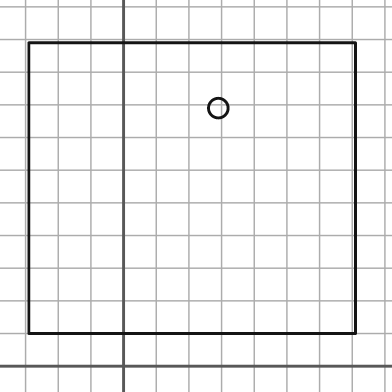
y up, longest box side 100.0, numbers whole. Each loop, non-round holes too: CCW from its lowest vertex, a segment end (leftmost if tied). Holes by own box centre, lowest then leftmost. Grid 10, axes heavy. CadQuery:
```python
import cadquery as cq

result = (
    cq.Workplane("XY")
    .moveTo(-29.0, 10.0)
    .lineTo(71.0, 10.0)
    .lineTo(71.0, 99.0)
    .lineTo(-29.0, 99.0)
    .close()
    .moveTo(29.0, 79.0)
    .circle(3.0)
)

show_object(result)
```